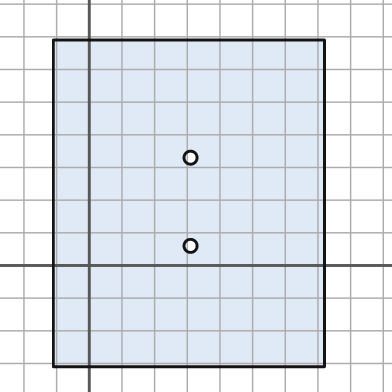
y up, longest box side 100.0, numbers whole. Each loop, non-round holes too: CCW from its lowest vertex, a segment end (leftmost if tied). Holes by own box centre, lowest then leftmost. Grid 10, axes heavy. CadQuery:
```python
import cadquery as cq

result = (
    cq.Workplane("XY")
    .moveTo(-11.0, -31.0)
    .lineTo(72.0, -31.0)
    .lineTo(72.0, 69.0)
    .lineTo(-11.0, 69.0)
    .close()
    .moveTo(31.0, 6.0)
    .circle(2.0)
    .moveTo(31.0, 33.0)
    .circle(2.0)
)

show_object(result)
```